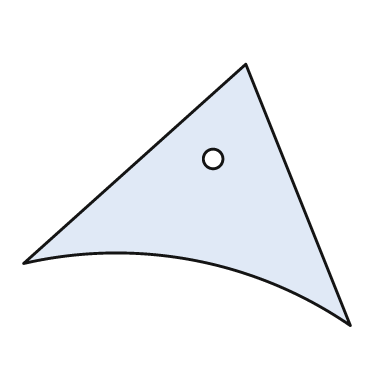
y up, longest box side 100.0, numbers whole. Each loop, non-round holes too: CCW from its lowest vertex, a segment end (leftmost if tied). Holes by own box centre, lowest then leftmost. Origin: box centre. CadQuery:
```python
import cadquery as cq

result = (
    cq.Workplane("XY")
    .moveTo(50.0, -40.0)
    .lineTo(18.0, 40.0)
    .lineTo(-50.0, -21.0)
    .threePointArc((2.0, -20.0), (50.0, -40.0))
    .close()
    .moveTo(8.0, 11.0)
    .circle(3.0)
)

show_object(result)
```